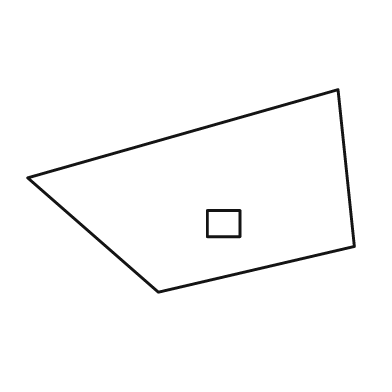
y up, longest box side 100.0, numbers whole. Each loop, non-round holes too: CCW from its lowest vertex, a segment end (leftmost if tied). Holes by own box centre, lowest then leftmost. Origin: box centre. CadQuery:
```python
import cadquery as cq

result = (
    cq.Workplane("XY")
    .moveTo(-10.0, -31.0)
    .lineTo(50.0, -17.0)
    .lineTo(45.0, 31.0)
    .lineTo(-50.0, 4.0)
    .close()
    .moveTo(5.0, -14.0)
    .lineTo(15.0, -14.0)
    .lineTo(15.0, -6.0)
    .lineTo(5.0, -6.0)
    .close()
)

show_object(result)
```